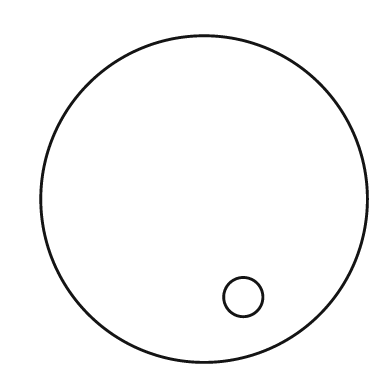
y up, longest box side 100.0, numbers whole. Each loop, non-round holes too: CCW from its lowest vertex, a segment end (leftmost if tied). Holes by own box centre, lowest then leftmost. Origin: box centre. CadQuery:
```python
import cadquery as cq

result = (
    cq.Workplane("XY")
    .moveTo(0.0, 0.0)
    .circle(50.0)
    .moveTo(12.0, -30.0)
    .circle(6.0)
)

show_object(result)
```